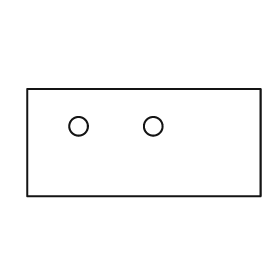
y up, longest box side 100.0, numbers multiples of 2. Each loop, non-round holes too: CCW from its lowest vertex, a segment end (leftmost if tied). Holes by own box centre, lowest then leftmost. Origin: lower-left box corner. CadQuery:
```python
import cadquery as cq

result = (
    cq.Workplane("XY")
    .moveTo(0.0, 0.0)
    .lineTo(100.0, 0.0)
    .lineTo(100.0, 46.0)
    .lineTo(0.0, 46.0)
    .close()
    .moveTo(22.0, 30.0)
    .circle(4.0)
    .moveTo(54.0, 30.0)
    .circle(4.0)
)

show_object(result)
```